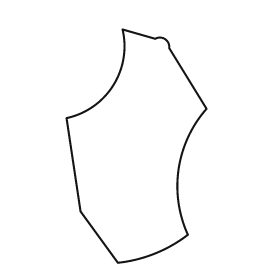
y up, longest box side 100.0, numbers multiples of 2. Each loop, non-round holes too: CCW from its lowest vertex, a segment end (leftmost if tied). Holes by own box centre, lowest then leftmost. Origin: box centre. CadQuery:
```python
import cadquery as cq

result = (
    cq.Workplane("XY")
    .moveTo(-8.0, -50.0)
    .threePointArc((8.0, -46.0), (22.0, -38.0))
    .threePointArc((18.0, -10.0), (30.0, 16.0))
    .lineTo(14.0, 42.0)
    .threePointArc((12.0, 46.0), (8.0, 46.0))
    .lineTo(-6.0, 50.0)
    .threePointArc((-10.0, 26.0), (-30.0, 12.0))
    .lineTo(-24.0, -28.0)
    .close()
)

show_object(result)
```